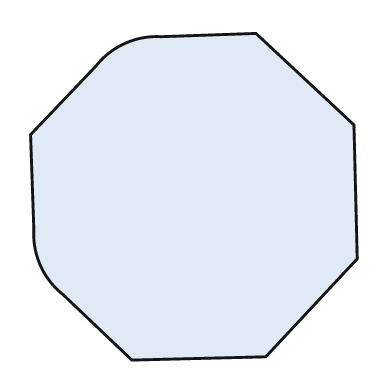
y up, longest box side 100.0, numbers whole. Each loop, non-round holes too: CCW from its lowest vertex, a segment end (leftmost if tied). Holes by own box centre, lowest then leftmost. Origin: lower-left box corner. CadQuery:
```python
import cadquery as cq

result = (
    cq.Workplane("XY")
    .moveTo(31.0, 0.0)
    .lineTo(72.0, 1.0)
    .lineTo(100.0, 31.0)
    .lineTo(99.0, 72.0)
    .lineTo(69.0, 100.0)
    .lineTo(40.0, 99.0)
    .threePointArc((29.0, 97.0), (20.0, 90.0))
    .lineTo(0.0, 69.0)
    .lineTo(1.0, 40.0)
    .threePointArc((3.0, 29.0), (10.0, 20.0))
    .close()
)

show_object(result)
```